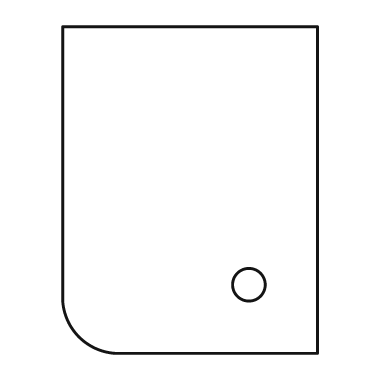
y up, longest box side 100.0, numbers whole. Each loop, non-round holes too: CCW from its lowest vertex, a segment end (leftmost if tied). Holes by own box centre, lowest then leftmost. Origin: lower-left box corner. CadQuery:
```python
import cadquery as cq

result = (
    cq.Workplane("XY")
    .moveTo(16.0, 0.0)
    .lineTo(78.0, 0.0)
    .lineTo(78.0, 100.0)
    .lineTo(0.0, 100.0)
    .lineTo(0.0, 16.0)
    .threePointArc((5.0, 5.0), (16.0, 0.0))
    .close()
    .moveTo(57.0, 21.0)
    .circle(5.0)
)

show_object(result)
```